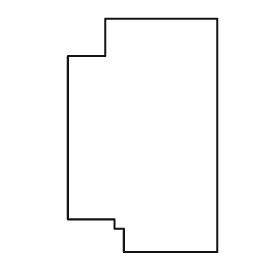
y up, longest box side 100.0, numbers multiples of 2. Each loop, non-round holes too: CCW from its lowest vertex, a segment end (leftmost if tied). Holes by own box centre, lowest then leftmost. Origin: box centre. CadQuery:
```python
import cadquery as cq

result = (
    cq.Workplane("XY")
    .moveTo(-8.0, -50.0)
    .lineTo(32.0, -50.0)
    .lineTo(32.0, 50.0)
    .lineTo(-16.0, 50.0)
    .lineTo(-16.0, 34.0)
    .lineTo(-32.0, 34.0)
    .lineTo(-32.0, -36.0)
    .lineTo(-12.0, -36.0)
    .lineTo(-12.0, -40.0)
    .lineTo(-8.0, -40.0)
    .close()
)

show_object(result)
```